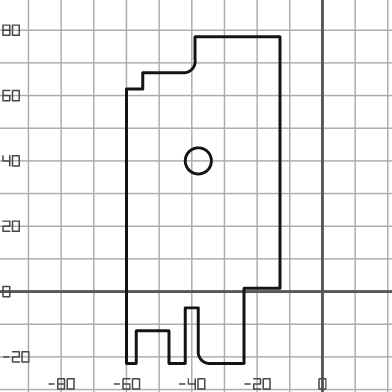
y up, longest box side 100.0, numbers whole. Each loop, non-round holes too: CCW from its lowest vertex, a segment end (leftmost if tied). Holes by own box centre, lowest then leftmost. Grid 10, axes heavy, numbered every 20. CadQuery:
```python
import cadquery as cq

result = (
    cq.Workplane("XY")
    .moveTo(-60.0, -22.0)
    .lineTo(-57.0, -22.0)
    .lineTo(-57.0, -12.0)
    .lineTo(-47.0, -12.0)
    .lineTo(-47.0, -22.0)
    .lineTo(-42.0, -22.0)
    .lineTo(-42.0, -5.0)
    .lineTo(-38.0, -5.0)
    .lineTo(-38.0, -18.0)
    .threePointArc((-37.0, -21.0), (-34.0, -22.0))
    .lineTo(-24.0, -22.0)
    .lineTo(-24.0, 1.0)
    .lineTo(-13.0, 1.0)
    .lineTo(-13.0, 78.0)
    .lineTo(-39.0, 78.0)
    .lineTo(-39.0, 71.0)
    .threePointArc((-40.0, 68.0), (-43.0, 67.0))
    .lineTo(-55.0, 67.0)
    .lineTo(-55.0, 62.0)
    .lineTo(-60.0, 62.0)
    .close()
    .moveTo(-38.0, 40.0)
    .circle(4.0)
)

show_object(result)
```